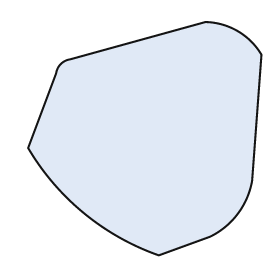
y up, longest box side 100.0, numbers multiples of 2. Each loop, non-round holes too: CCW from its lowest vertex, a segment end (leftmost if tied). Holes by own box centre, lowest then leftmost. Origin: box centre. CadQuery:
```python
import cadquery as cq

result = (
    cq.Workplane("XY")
    .moveTo(6.0, -50.0)
    .lineTo(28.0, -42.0)
    .threePointArc((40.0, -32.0), (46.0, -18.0))
    .lineTo(50.0, 36.0)
    .threePointArc((40.0, 46.0), (26.0, 50.0))
    .lineTo(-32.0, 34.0)
    .threePointArc((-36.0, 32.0), (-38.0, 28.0))
    .lineTo(-50.0, -4.0)
    .threePointArc((-26.0, -32.0), (6.0, -50.0))
    .close()
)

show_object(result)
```